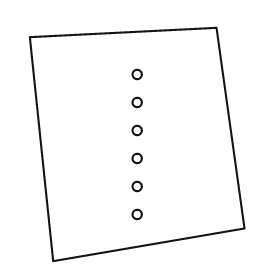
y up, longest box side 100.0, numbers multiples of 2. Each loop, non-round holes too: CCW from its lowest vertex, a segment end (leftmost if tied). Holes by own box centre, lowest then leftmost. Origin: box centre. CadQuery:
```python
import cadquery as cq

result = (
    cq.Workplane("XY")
    .moveTo(-36.0, -50.0)
    .lineTo(46.0, -36.0)
    .lineTo(34.0, 50.0)
    .lineTo(-46.0, 46.0)
    .close()
    .moveTo(0.0, -30.0)
    .circle(2.0)
    .moveTo(0.0, -18.0)
    .circle(2.0)
    .moveTo(0.0, -6.0)
    .circle(2.0)
    .moveTo(0.0, 6.0)
    .circle(2.0)
    .moveTo(0.0, 18.0)
    .circle(2.0)
    .moveTo(0.0, 30.0)
    .circle(2.0)
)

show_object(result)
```